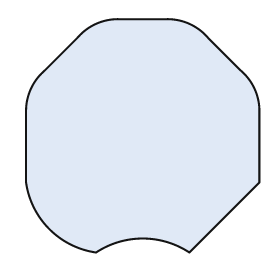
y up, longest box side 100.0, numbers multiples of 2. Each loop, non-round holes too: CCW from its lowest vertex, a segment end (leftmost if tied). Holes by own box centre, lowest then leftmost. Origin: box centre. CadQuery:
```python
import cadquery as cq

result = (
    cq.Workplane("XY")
    .moveTo(-20.0, -50.0)
    .threePointArc((0.0, -44.0), (20.0, -50.0))
    .lineTo(50.0, -20.0)
    .lineTo(50.0, 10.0)
    .threePointArc((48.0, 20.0), (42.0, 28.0))
    .lineTo(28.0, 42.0)
    .threePointArc((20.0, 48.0), (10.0, 50.0))
    .lineTo(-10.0, 50.0)
    .threePointArc((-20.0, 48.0), (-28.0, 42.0))
    .lineTo(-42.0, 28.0)
    .threePointArc((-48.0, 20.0), (-50.0, 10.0))
    .lineTo(-50.0, -20.0)
    .threePointArc((-40.0, -40.0), (-20.0, -50.0))
    .close()
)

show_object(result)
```